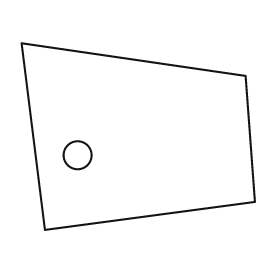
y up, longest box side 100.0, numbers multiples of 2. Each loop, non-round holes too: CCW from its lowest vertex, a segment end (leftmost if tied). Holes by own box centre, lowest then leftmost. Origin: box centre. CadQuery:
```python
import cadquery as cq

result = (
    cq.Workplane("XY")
    .moveTo(-40.0, -40.0)
    .lineTo(50.0, -28.0)
    .lineTo(46.0, 26.0)
    .lineTo(-50.0, 40.0)
    .close()
    .moveTo(-26.0, -8.0)
    .circle(6.0)
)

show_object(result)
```